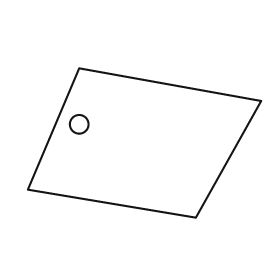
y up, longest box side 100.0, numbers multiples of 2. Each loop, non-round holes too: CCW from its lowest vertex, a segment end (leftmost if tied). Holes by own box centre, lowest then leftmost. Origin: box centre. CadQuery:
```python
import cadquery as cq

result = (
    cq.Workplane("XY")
    .moveTo(22.0, -32.0)
    .lineTo(50.0, 18.0)
    .lineTo(-28.0, 32.0)
    .lineTo(-50.0, -20.0)
    .close()
    .moveTo(-28.0, 8.0)
    .circle(4.0)
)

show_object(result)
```